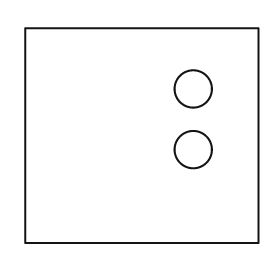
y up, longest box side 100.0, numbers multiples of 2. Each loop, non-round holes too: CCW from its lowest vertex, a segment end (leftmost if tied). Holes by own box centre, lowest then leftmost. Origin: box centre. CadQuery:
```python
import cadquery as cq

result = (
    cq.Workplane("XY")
    .moveTo(-50.0, -46.0)
    .lineTo(50.0, -46.0)
    .lineTo(50.0, 46.0)
    .lineTo(-50.0, 46.0)
    .close()
    .moveTo(22.0, -6.0)
    .circle(8.0)
    .moveTo(22.0, 20.0)
    .circle(8.0)
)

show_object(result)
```